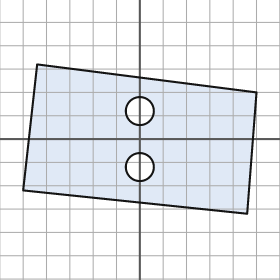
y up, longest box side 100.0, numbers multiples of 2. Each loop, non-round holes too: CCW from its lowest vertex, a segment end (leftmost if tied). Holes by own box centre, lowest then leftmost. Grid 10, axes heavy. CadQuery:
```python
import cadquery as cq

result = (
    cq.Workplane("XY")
    .moveTo(46.0, -32.0)
    .lineTo(50.0, 20.0)
    .lineTo(-44.0, 32.0)
    .lineTo(-50.0, -22.0)
    .close()
    .moveTo(0.0, -12.0)
    .circle(6.0)
    .moveTo(0.0, 12.0)
    .circle(6.0)
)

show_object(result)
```